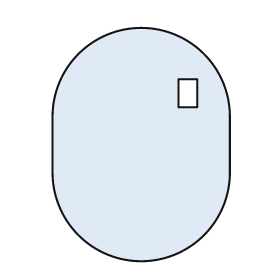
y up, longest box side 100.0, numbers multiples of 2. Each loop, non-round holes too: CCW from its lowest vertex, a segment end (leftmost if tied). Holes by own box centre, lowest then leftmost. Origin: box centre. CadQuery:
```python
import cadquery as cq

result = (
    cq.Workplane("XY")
    .moveTo(-38.0, -12.0)
    .threePointArc((0.0, -50.0), (38.0, -12.0))
    .lineTo(38.0, 12.0)
    .threePointArc((0.0, 50.0), (-38.0, 12.0))
    .close()
    .moveTo(16.0, 16.0)
    .lineTo(24.0, 16.0)
    .lineTo(24.0, 28.0)
    .lineTo(16.0, 28.0)
    .close()
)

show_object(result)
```